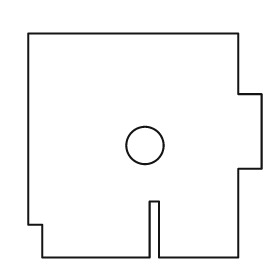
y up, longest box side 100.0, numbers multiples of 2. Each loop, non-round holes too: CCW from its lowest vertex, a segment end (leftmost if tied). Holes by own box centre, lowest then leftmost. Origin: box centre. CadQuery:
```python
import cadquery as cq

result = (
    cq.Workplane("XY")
    .moveTo(-44.0, -48.0)
    .lineTo(2.0, -48.0)
    .lineTo(2.0, -24.0)
    .lineTo(6.0, -24.0)
    .lineTo(6.0, -48.0)
    .lineTo(40.0, -48.0)
    .lineTo(40.0, -10.0)
    .lineTo(50.0, -10.0)
    .lineTo(50.0, 22.0)
    .lineTo(40.0, 22.0)
    .lineTo(40.0, 48.0)
    .lineTo(-50.0, 48.0)
    .lineTo(-50.0, -34.0)
    .lineTo(-44.0, -34.0)
    .close()
    .moveTo(0.0, 0.0)
    .circle(8.0)
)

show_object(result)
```